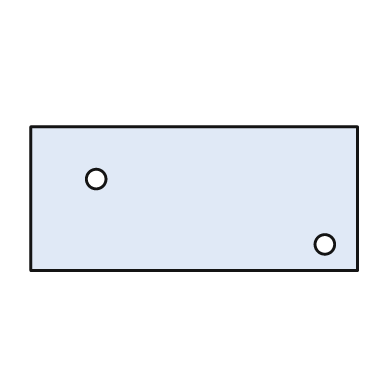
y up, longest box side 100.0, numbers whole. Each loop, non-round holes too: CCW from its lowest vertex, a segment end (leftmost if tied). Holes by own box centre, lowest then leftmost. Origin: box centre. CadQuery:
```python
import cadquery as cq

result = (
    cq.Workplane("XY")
    .moveTo(-50.0, -22.0)
    .lineTo(50.0, -22.0)
    .lineTo(50.0, 22.0)
    .lineTo(-50.0, 22.0)
    .close()
    .moveTo(40.0, -14.0)
    .circle(3.0)
    .moveTo(-30.0, 6.0)
    .circle(3.0)
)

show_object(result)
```